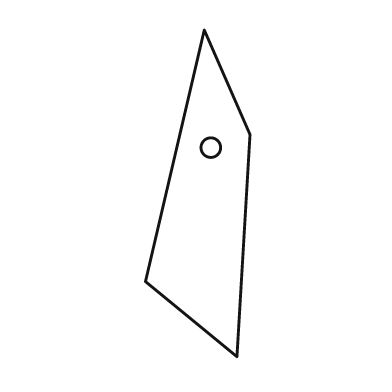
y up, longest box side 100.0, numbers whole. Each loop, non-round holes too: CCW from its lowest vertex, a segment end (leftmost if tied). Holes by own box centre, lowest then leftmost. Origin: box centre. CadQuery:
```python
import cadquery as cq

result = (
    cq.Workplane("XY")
    .moveTo(12.0, -50.0)
    .lineTo(16.0, 18.0)
    .lineTo(2.0, 50.0)
    .lineTo(-16.0, -27.0)
    .close()
    .moveTo(4.0, 14.0)
    .circle(3.0)
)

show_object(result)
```